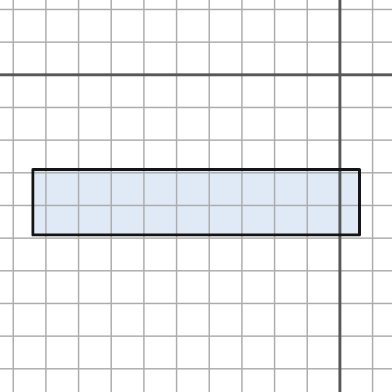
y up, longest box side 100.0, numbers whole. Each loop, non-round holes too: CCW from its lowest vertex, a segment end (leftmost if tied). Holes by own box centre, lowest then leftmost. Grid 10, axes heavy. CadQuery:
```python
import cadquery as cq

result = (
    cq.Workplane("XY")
    .moveTo(-94.0, -49.0)
    .lineTo(6.0, -49.0)
    .lineTo(6.0, -29.0)
    .lineTo(-94.0, -29.0)
    .close()
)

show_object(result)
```